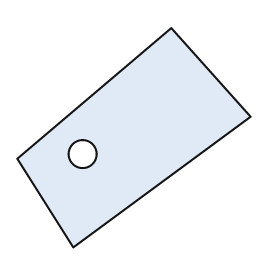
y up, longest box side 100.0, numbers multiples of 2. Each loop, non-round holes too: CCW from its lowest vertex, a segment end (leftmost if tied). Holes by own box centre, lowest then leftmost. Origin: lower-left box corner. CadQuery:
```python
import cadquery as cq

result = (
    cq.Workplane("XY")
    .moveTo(24.0, 0.0)
    .lineTo(100.0, 56.0)
    .lineTo(66.0, 94.0)
    .lineTo(0.0, 38.0)
    .close()
    .moveTo(28.0, 40.0)
    .circle(6.0)
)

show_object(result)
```